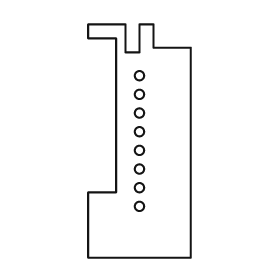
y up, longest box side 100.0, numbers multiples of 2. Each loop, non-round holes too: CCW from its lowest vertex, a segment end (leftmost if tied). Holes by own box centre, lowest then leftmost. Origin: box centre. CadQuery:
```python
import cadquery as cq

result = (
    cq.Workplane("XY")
    .moveTo(-22.0, -50.0)
    .lineTo(22.0, -50.0)
    .lineTo(22.0, 40.0)
    .lineTo(6.0, 40.0)
    .lineTo(6.0, 50.0)
    .lineTo(0.0, 50.0)
    .lineTo(0.0, 38.0)
    .lineTo(-6.0, 38.0)
    .lineTo(-6.0, 50.0)
    .lineTo(-22.0, 50.0)
    .lineTo(-22.0, 44.0)
    .lineTo(-10.0, 44.0)
    .lineTo(-10.0, -22.0)
    .lineTo(-22.0, -22.0)
    .close()
    .moveTo(0.0, -28.0)
    .circle(2.0)
    .moveTo(0.0, -20.0)
    .circle(2.0)
    .moveTo(0.0, -12.0)
    .circle(2.0)
    .moveTo(0.0, -4.0)
    .circle(2.0)
    .moveTo(0.0, 4.0)
    .circle(2.0)
    .moveTo(0.0, 12.0)
    .circle(2.0)
    .moveTo(0.0, 20.0)
    .circle(2.0)
    .moveTo(0.0, 28.0)
    .circle(2.0)
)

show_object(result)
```